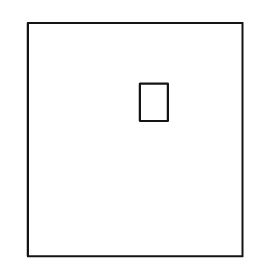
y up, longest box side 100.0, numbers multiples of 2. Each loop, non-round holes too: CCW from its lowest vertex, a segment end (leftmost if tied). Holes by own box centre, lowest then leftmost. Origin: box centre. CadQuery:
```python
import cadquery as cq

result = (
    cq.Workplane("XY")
    .moveTo(-46.0, -50.0)
    .lineTo(46.0, -50.0)
    .lineTo(46.0, 50.0)
    .lineTo(-46.0, 50.0)
    .close()
    .moveTo(2.0, 8.0)
    .lineTo(14.0, 8.0)
    .lineTo(14.0, 24.0)
    .lineTo(2.0, 24.0)
    .close()
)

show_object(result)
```